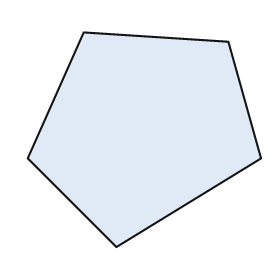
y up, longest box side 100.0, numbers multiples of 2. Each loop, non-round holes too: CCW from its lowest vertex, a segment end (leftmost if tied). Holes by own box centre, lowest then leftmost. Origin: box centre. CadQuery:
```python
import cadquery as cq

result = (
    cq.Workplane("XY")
    .moveTo(-12.0, -46.0)
    .lineTo(50.0, -8.0)
    .lineTo(36.0, 42.0)
    .lineTo(-26.0, 46.0)
    .lineTo(-50.0, -8.0)
    .close()
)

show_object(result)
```